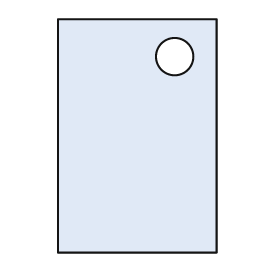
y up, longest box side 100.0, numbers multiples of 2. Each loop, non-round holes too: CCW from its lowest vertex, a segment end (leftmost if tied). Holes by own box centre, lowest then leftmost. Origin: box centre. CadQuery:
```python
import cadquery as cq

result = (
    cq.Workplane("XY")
    .moveTo(-34.0, -50.0)
    .lineTo(34.0, -50.0)
    .lineTo(34.0, 50.0)
    .lineTo(-34.0, 50.0)
    .close()
    .moveTo(16.0, 34.0)
    .circle(8.0)
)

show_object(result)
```